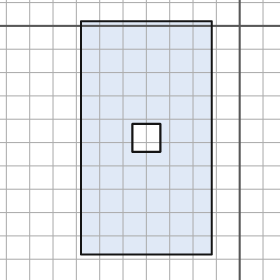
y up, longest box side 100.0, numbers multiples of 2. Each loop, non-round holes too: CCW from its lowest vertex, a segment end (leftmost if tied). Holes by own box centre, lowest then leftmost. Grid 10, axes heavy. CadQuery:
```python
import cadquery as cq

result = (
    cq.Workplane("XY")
    .moveTo(-68.0, -98.0)
    .lineTo(-12.0, -98.0)
    .lineTo(-12.0, 2.0)
    .lineTo(-68.0, 2.0)
    .close()
    .moveTo(-46.0, -54.0)
    .lineTo(-34.0, -54.0)
    .lineTo(-34.0, -42.0)
    .lineTo(-46.0, -42.0)
    .close()
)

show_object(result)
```